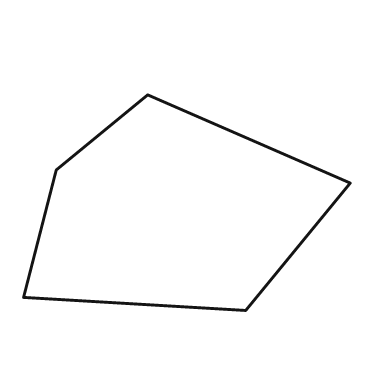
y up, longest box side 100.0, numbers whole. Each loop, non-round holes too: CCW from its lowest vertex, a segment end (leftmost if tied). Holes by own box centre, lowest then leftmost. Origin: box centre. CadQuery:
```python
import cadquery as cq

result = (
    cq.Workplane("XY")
    .moveTo(18.0, -33.0)
    .lineTo(50.0, 6.0)
    .lineTo(-12.0, 33.0)
    .lineTo(-40.0, 10.0)
    .lineTo(-50.0, -29.0)
    .close()
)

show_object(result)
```